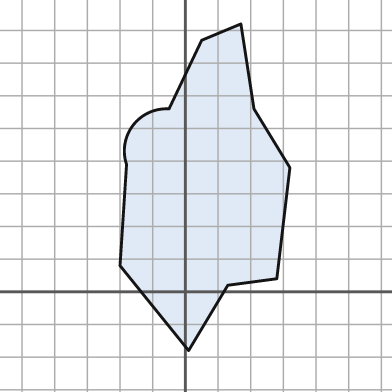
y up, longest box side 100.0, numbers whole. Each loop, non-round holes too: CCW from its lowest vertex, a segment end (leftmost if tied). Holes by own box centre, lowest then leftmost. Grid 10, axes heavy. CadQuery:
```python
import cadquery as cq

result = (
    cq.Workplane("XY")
    .moveTo(1.0, -18.0)
    .lineTo(13.0, 2.0)
    .lineTo(28.0, 4.0)
    .lineTo(32.0, 38.0)
    .lineTo(21.0, 56.0)
    .lineTo(17.0, 82.0)
    .lineTo(5.0, 77.0)
    .lineTo(-5.0, 56.0)
    .threePointArc((-16.0, 51.0), (-18.0, 39.0))
    .lineTo(-20.0, 8.0)
    .close()
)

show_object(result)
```